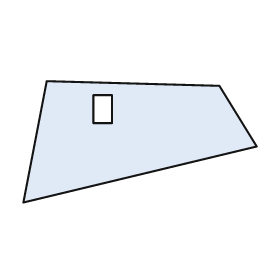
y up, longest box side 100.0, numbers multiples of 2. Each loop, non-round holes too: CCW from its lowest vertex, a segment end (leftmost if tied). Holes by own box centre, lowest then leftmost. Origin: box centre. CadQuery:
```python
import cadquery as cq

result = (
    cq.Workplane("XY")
    .moveTo(-50.0, -26.0)
    .lineTo(50.0, -2.0)
    .lineTo(34.0, 24.0)
    .lineTo(-40.0, 26.0)
    .close()
    .moveTo(-20.0, 8.0)
    .lineTo(-12.0, 8.0)
    .lineTo(-12.0, 20.0)
    .lineTo(-20.0, 20.0)
    .close()
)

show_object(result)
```